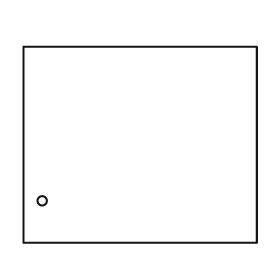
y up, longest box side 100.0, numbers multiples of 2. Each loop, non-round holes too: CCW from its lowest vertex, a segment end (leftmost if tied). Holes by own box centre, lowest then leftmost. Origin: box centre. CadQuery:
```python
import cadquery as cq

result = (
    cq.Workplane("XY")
    .moveTo(-50.0, -42.0)
    .lineTo(50.0, -42.0)
    .lineTo(50.0, 42.0)
    .lineTo(-50.0, 42.0)
    .close()
    .moveTo(-42.0, -24.0)
    .circle(2.0)
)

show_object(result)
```